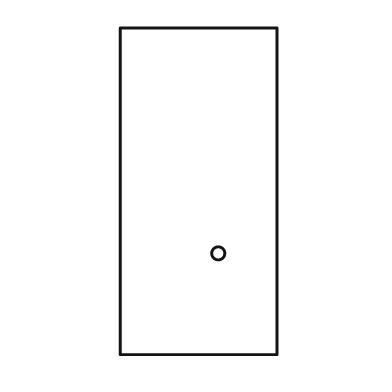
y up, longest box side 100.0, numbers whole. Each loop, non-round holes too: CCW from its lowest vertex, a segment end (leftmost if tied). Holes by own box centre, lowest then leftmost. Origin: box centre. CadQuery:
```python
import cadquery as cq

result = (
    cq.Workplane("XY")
    .moveTo(-24.0, -50.0)
    .lineTo(24.0, -50.0)
    .lineTo(24.0, 50.0)
    .lineTo(-24.0, 50.0)
    .close()
    .moveTo(6.0, -19.0)
    .circle(2.0)
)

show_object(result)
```